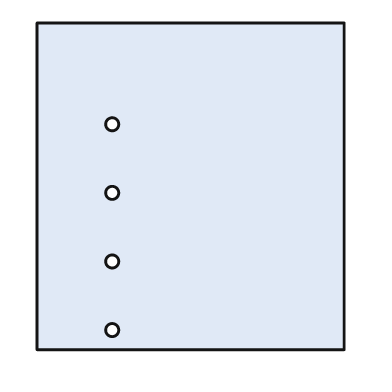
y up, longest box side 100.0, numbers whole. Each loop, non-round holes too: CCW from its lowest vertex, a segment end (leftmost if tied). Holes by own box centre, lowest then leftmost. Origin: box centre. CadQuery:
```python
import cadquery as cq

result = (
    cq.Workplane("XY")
    .moveTo(-47.0, -50.0)
    .lineTo(47.0, -50.0)
    .lineTo(47.0, 50.0)
    .lineTo(-47.0, 50.0)
    .close()
    .moveTo(-24.0, -44.0)
    .circle(2.0)
    .moveTo(-24.0, -23.0)
    .circle(2.0)
    .moveTo(-24.0, -2.0)
    .circle(2.0)
    .moveTo(-24.0, 19.0)
    .circle(2.0)
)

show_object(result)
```